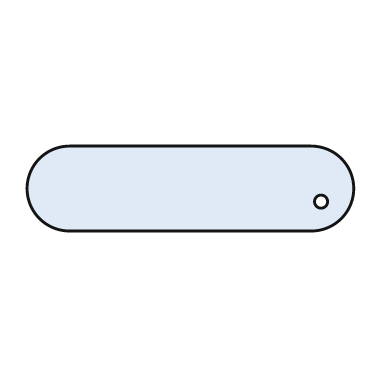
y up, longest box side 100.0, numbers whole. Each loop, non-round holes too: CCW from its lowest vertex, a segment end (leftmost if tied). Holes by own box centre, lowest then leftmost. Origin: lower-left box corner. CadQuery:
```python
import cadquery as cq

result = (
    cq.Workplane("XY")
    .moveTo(13.0, 0.0)
    .lineTo(87.0, 0.0)
    .threePointArc((100.0, 13.0), (87.0, 26.0))
    .lineTo(13.0, 26.0)
    .threePointArc((0.0, 13.0), (13.0, 0.0))
    .close()
    .moveTo(90.0, 9.0)
    .circle(2.0)
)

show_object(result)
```